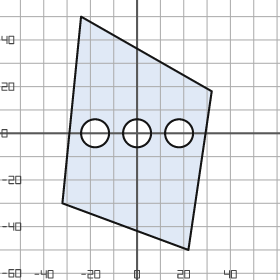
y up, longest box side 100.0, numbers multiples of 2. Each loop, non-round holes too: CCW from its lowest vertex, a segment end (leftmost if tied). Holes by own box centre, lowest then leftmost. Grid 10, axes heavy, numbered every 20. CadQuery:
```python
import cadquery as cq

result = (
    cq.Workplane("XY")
    .moveTo(22.0, -50.0)
    .lineTo(32.0, 18.0)
    .lineTo(-24.0, 50.0)
    .lineTo(-32.0, -30.0)
    .close()
    .moveTo(-18.0, 0.0)
    .circle(6.0)
    .moveTo(0.0, 0.0)
    .circle(6.0)
    .moveTo(18.0, 0.0)
    .circle(6.0)
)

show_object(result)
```